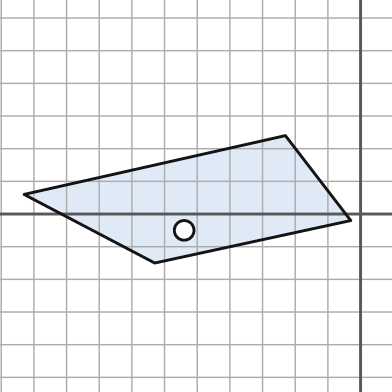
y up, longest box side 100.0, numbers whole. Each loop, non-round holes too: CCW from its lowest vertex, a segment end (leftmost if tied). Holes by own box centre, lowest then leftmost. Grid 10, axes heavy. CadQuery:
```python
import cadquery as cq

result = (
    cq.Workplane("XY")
    .moveTo(-63.0, -15.0)
    .lineTo(-3.0, -2.0)
    .lineTo(-23.0, 24.0)
    .lineTo(-103.0, 6.0)
    .close()
    .moveTo(-54.0, -5.0)
    .circle(3.0)
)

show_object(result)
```